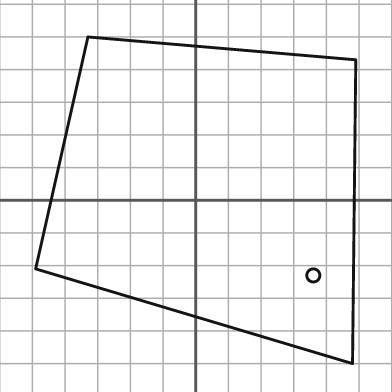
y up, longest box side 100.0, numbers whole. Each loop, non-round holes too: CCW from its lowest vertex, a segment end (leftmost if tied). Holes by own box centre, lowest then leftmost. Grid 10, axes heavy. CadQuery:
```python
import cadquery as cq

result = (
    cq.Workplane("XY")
    .moveTo(48.0, -50.0)
    .lineTo(49.0, 43.0)
    .lineTo(-33.0, 50.0)
    .lineTo(-49.0, -21.0)
    .close()
    .moveTo(36.0, -23.0)
    .circle(2.0)
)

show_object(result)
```